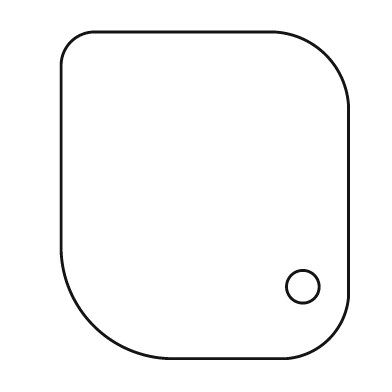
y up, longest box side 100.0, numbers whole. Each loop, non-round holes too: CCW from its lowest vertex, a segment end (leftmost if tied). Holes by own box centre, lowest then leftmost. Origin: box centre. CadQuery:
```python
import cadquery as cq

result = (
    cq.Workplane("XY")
    .moveTo(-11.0, -50.0)
    .lineTo(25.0, -50.0)
    .threePointArc((38.0, -44.0), (44.0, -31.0))
    .lineTo(44.0, 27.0)
    .threePointArc((37.0, 43.0), (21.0, 50.0))
    .lineTo(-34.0, 50.0)
    .threePointArc((-41.0, 47.0), (-44.0, 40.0))
    .lineTo(-44.0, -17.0)
    .threePointArc((-34.0, -40.0), (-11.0, -50.0))
    .close()
    .moveTo(30.0, -28.0)
    .circle(5.0)
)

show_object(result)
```